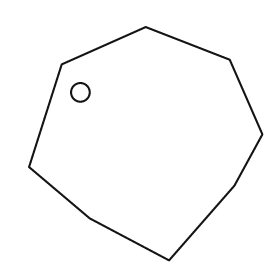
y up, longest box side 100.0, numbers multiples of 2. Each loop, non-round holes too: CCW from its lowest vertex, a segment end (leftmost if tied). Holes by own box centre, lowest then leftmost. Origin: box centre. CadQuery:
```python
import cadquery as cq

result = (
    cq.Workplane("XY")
    .moveTo(10.0, -50.0)
    .lineTo(38.0, -18.0)
    .lineTo(50.0, 4.0)
    .lineTo(36.0, 36.0)
    .lineTo(0.0, 50.0)
    .lineTo(-36.0, 34.0)
    .lineTo(-50.0, -10.0)
    .lineTo(-24.0, -32.0)
    .close()
    .moveTo(-28.0, 22.0)
    .circle(4.0)
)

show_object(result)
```